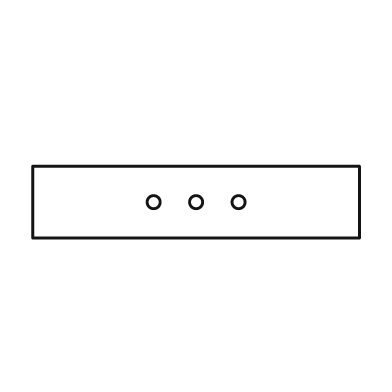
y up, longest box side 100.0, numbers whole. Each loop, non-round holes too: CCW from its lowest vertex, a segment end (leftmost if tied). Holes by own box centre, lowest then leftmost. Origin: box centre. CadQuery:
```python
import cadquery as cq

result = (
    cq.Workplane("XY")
    .moveTo(-50.0, -11.0)
    .lineTo(50.0, -11.0)
    .lineTo(50.0, 11.0)
    .lineTo(-50.0, 11.0)
    .close()
    .moveTo(-13.0, 0.0)
    .circle(2.0)
    .moveTo(0.0, 0.0)
    .circle(2.0)
    .moveTo(13.0, 0.0)
    .circle(2.0)
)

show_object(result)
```